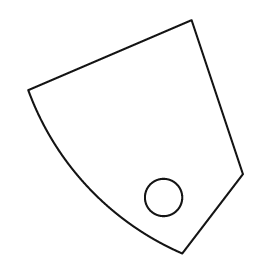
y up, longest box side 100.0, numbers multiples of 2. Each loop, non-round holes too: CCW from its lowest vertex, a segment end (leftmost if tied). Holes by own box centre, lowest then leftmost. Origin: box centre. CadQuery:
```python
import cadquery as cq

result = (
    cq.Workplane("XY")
    .moveTo(20.0, -50.0)
    .lineTo(46.0, -16.0)
    .lineTo(24.0, 50.0)
    .lineTo(-46.0, 20.0)
    .threePointArc((-20.0, -22.0), (20.0, -50.0))
    .close()
    .moveTo(12.0, -26.0)
    .circle(8.0)
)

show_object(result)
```